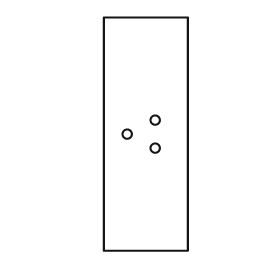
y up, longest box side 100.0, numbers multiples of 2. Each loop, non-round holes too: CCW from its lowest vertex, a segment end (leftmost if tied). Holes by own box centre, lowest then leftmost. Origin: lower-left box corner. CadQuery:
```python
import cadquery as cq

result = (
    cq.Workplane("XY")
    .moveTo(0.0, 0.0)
    .lineTo(36.0, 0.0)
    .lineTo(36.0, 100.0)
    .lineTo(0.0, 100.0)
    .close()
    .moveTo(22.0, 44.0)
    .circle(2.0)
    .moveTo(10.0, 50.0)
    .circle(2.0)
    .moveTo(22.0, 56.0)
    .circle(2.0)
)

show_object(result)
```